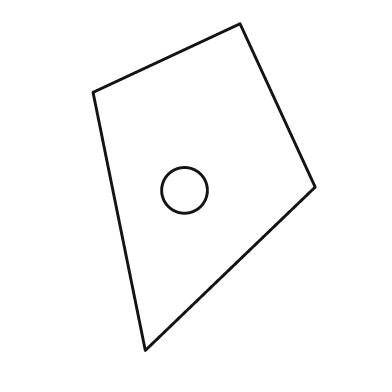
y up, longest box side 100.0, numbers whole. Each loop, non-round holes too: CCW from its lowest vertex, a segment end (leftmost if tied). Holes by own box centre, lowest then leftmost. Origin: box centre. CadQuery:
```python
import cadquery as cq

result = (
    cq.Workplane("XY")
    .moveTo(-18.0, -50.0)
    .lineTo(34.0, 0.0)
    .lineTo(11.0, 50.0)
    .lineTo(-34.0, 29.0)
    .close()
    .moveTo(-6.0, -1.0)
    .circle(7.0)
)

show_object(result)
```